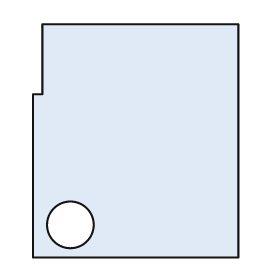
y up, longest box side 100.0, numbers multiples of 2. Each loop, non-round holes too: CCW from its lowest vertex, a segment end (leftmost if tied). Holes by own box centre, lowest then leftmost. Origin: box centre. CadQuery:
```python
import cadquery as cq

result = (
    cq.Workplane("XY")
    .moveTo(-44.0, -50.0)
    .lineTo(44.0, -50.0)
    .lineTo(44.0, 50.0)
    .lineTo(-40.0, 50.0)
    .lineTo(-40.0, 20.0)
    .lineTo(-44.0, 20.0)
    .close()
    .moveTo(-28.0, -36.0)
    .circle(10.0)
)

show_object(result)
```